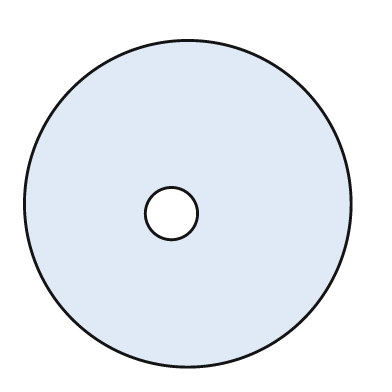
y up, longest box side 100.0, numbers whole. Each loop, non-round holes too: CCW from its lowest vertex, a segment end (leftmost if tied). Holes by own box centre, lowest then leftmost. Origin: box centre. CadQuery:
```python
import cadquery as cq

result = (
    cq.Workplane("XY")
    .moveTo(0.0, 0.0)
    .circle(50.0)
    .moveTo(-5.0, -3.0)
    .circle(8.0)
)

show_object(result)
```